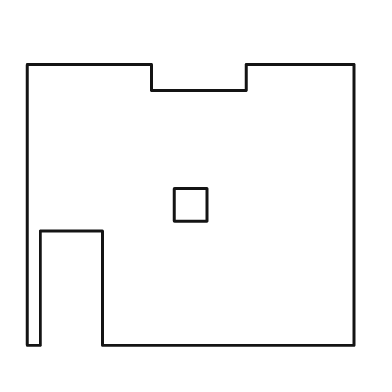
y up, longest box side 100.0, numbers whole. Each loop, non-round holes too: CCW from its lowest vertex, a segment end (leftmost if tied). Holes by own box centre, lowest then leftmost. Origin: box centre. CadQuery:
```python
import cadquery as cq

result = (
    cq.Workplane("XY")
    .moveTo(-50.0, -43.0)
    .lineTo(-46.0, -43.0)
    .lineTo(-46.0, -8.0)
    .lineTo(-27.0, -8.0)
    .lineTo(-27.0, -43.0)
    .lineTo(50.0, -43.0)
    .lineTo(50.0, 43.0)
    .lineTo(17.0, 43.0)
    .lineTo(17.0, 35.0)
    .lineTo(-12.0, 35.0)
    .lineTo(-12.0, 43.0)
    .lineTo(-50.0, 43.0)
    .close()
    .moveTo(-5.0, -5.0)
    .lineTo(5.0, -5.0)
    .lineTo(5.0, 5.0)
    .lineTo(-5.0, 5.0)
    .close()
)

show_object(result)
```